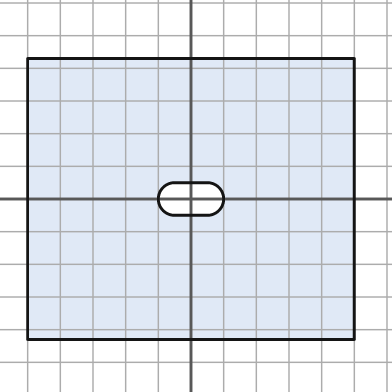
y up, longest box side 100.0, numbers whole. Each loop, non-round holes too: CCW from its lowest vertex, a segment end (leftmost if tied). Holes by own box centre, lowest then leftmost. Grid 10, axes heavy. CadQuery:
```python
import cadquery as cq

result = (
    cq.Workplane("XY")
    .moveTo(-50.0, -43.0)
    .lineTo(50.0, -43.0)
    .lineTo(50.0, 43.0)
    .lineTo(-50.0, 43.0)
    .close()
    .moveTo(-5.0, -5.0)
    .lineTo(5.0, -5.0)
    .threePointArc((10.0, 0.0), (5.0, 5.0))
    .lineTo(-5.0, 5.0)
    .threePointArc((-10.0, 0.0), (-5.0, -5.0))
    .close()
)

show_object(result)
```